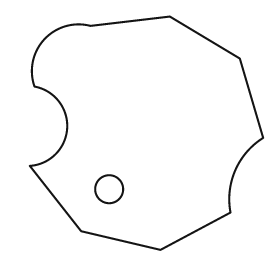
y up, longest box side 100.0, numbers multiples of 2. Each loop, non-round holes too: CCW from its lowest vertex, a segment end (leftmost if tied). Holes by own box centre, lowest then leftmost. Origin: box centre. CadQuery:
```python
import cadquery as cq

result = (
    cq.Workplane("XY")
    .moveTo(6.0, -50.0)
    .lineTo(36.0, -34.0)
    .threePointArc((38.0, -16.0), (50.0, -2.0))
    .lineTo(40.0, 32.0)
    .lineTo(10.0, 50.0)
    .lineTo(-24.0, 46.0)
    .threePointArc((-44.0, 40.0), (-48.0, 20.0))
    .threePointArc((-34.0, 2.0), (-50.0, -14.0))
    .lineTo(-28.0, -42.0)
    .close()
    .moveTo(-16.0, -24.0)
    .circle(6.0)
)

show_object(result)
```